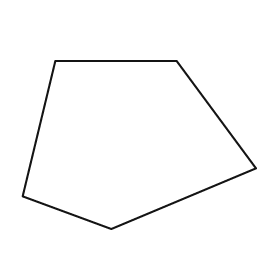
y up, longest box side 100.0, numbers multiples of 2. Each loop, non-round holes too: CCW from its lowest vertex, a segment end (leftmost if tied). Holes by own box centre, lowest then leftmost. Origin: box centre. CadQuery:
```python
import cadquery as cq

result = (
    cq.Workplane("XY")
    .moveTo(-12.0, -36.0)
    .lineTo(50.0, -10.0)
    .lineTo(16.0, 36.0)
    .lineTo(-36.0, 36.0)
    .lineTo(-50.0, -22.0)
    .close()
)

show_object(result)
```